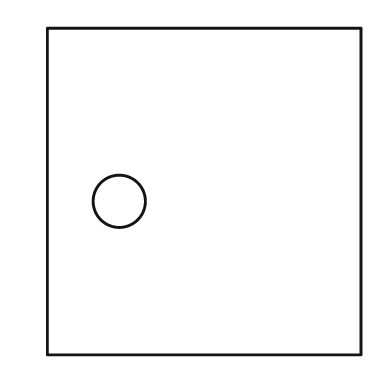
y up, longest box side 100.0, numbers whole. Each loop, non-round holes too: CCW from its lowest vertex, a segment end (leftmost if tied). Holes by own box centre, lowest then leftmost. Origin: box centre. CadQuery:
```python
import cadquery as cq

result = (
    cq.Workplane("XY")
    .moveTo(-48.0, -50.0)
    .lineTo(48.0, -50.0)
    .lineTo(48.0, 50.0)
    .lineTo(-48.0, 50.0)
    .close()
    .moveTo(-26.0, -3.0)
    .circle(8.0)
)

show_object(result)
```